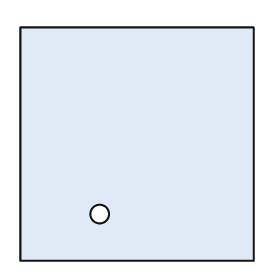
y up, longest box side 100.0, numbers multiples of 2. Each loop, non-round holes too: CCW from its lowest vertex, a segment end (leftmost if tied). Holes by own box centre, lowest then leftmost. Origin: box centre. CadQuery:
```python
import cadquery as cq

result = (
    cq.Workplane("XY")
    .moveTo(-50.0, -50.0)
    .lineTo(50.0, -50.0)
    .lineTo(50.0, 50.0)
    .lineTo(-50.0, 50.0)
    .close()
    .moveTo(-16.0, -30.0)
    .circle(4.0)
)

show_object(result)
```